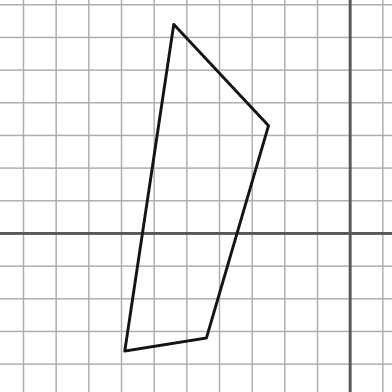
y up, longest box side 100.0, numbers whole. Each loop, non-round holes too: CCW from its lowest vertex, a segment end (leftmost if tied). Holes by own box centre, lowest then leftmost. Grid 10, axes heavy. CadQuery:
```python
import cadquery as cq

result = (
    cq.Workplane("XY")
    .moveTo(-69.0, -36.0)
    .lineTo(-44.0, -32.0)
    .lineTo(-25.0, 33.0)
    .lineTo(-54.0, 64.0)
    .close()
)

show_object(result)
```